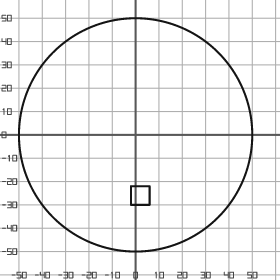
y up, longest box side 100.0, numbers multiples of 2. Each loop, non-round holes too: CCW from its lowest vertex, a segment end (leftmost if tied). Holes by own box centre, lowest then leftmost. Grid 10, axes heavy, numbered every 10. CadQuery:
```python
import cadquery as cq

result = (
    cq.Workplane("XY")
    .moveTo(0.0, 0.0)
    .circle(50.0)
    .moveTo(-2.0, -30.0)
    .lineTo(6.0, -30.0)
    .lineTo(6.0, -22.0)
    .lineTo(-2.0, -22.0)
    .close()
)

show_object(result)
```